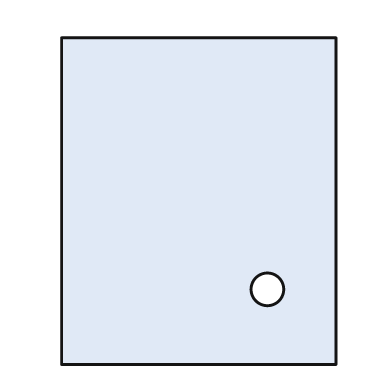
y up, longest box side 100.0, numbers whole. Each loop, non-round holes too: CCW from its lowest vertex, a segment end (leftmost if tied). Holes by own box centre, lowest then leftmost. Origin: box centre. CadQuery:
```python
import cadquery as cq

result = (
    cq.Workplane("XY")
    .moveTo(-42.0, -50.0)
    .lineTo(42.0, -50.0)
    .lineTo(42.0, 50.0)
    .lineTo(-42.0, 50.0)
    .close()
    .moveTo(21.0, -27.0)
    .circle(5.0)
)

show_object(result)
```